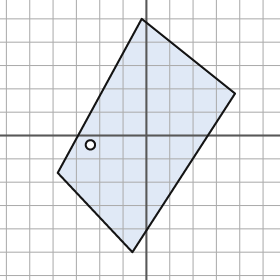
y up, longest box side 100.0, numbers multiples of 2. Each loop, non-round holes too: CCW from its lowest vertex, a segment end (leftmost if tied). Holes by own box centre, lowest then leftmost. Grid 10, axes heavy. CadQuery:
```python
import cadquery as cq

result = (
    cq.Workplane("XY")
    .moveTo(-6.0, -50.0)
    .lineTo(38.0, 18.0)
    .lineTo(-2.0, 50.0)
    .lineTo(-38.0, -16.0)
    .close()
    .moveTo(-24.0, -4.0)
    .circle(2.0)
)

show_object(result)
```